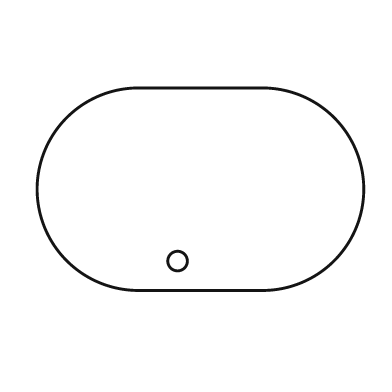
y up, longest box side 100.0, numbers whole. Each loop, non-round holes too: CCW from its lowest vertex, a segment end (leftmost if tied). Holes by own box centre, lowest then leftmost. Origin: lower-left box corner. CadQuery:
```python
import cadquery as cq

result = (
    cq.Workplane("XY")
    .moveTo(31.0, 0.0)
    .lineTo(69.0, 0.0)
    .threePointArc((100.0, 31.0), (69.0, 62.0))
    .lineTo(31.0, 62.0)
    .threePointArc((0.0, 31.0), (31.0, 0.0))
    .close()
    .moveTo(43.0, 9.0)
    .circle(3.0)
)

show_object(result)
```